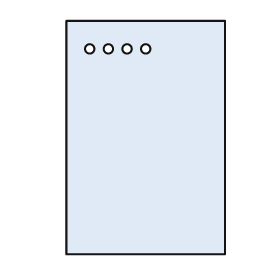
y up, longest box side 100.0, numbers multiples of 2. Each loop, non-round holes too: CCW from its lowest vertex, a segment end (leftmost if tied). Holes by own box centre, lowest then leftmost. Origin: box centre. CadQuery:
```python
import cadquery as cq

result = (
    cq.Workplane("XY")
    .moveTo(-34.0, -50.0)
    .lineTo(34.0, -50.0)
    .lineTo(34.0, 50.0)
    .lineTo(-34.0, 50.0)
    .close()
    .moveTo(-24.0, 38.0)
    .circle(2.0)
    .moveTo(-16.0, 38.0)
    .circle(2.0)
    .moveTo(-8.0, 38.0)
    .circle(2.0)
    .moveTo(0.0, 38.0)
    .circle(2.0)
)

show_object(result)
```